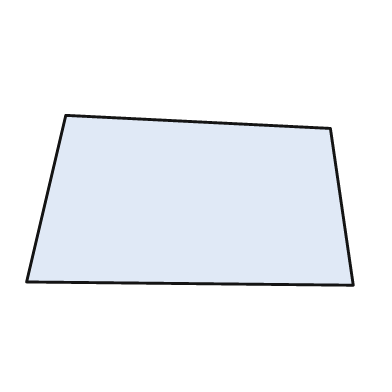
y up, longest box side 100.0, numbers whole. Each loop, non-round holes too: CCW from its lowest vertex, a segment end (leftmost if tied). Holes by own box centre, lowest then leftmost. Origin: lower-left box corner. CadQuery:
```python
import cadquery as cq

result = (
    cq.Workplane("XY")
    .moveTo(100.0, 0.0)
    .lineTo(93.0, 48.0)
    .lineTo(12.0, 52.0)
    .lineTo(0.0, 1.0)
    .close()
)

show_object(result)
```